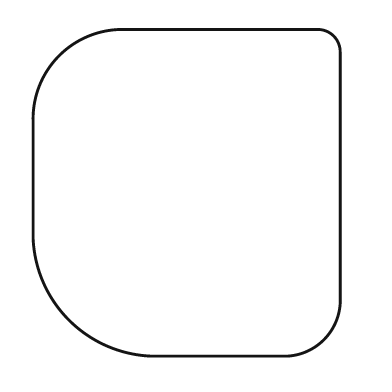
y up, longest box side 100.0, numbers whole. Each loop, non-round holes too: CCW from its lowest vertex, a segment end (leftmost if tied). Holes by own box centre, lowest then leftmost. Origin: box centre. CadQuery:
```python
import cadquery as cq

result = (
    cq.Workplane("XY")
    .moveTo(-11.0, -50.0)
    .lineTo(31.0, -50.0)
    .threePointArc((42.0, -45.0), (47.0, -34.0))
    .lineTo(47.0, 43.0)
    .threePointArc((45.0, 48.0), (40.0, 50.0))
    .lineTo(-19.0, 50.0)
    .threePointArc((-39.0, 42.0), (-47.0, 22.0))
    .lineTo(-47.0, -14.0)
    .threePointArc((-36.0, -39.0), (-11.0, -50.0))
    .close()
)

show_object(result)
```